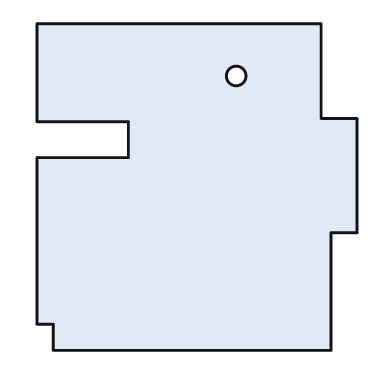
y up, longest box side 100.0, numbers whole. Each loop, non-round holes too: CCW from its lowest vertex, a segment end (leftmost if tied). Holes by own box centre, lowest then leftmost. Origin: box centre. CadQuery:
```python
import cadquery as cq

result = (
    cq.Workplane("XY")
    .moveTo(-44.0, -50.0)
    .lineTo(41.0, -50.0)
    .lineTo(41.0, -14.0)
    .lineTo(49.0, -14.0)
    .lineTo(49.0, 21.0)
    .lineTo(38.0, 21.0)
    .lineTo(38.0, 50.0)
    .lineTo(-49.0, 50.0)
    .lineTo(-49.0, 20.0)
    .lineTo(-21.0, 20.0)
    .lineTo(-21.0, 9.0)
    .lineTo(-49.0, 9.0)
    .lineTo(-49.0, -42.0)
    .lineTo(-44.0, -42.0)
    .close()
    .moveTo(12.0, 34.0)
    .circle(3.0)
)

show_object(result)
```